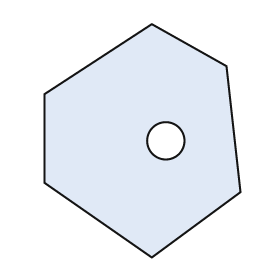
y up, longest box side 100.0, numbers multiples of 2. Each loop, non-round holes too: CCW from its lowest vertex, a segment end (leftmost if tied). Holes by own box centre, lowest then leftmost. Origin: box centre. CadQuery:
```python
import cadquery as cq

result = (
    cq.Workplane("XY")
    .moveTo(4.0, -50.0)
    .lineTo(42.0, -22.0)
    .lineTo(36.0, 32.0)
    .lineTo(4.0, 50.0)
    .lineTo(-42.0, 20.0)
    .lineTo(-42.0, -18.0)
    .close()
    .moveTo(10.0, 0.0)
    .circle(8.0)
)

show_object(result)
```